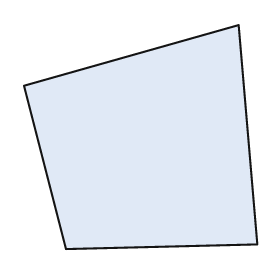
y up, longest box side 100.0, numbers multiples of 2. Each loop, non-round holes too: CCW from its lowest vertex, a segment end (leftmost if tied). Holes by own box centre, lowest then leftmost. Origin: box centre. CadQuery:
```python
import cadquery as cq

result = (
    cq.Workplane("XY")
    .moveTo(-32.0, -48.0)
    .lineTo(50.0, -46.0)
    .lineTo(42.0, 48.0)
    .lineTo(-50.0, 22.0)
    .close()
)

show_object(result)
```